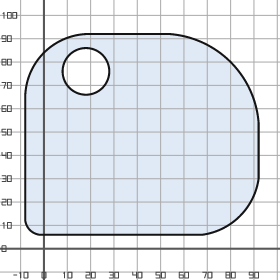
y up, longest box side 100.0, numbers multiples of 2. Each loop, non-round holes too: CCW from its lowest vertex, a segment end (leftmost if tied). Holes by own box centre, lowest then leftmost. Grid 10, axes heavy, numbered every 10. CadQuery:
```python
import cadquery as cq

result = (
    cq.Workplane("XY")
    .moveTo(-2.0, 6.0)
    .lineTo(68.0, 6.0)
    .threePointArc((84.0, 14.0), (92.0, 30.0))
    .lineTo(92.0, 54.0)
    .threePointArc((80.0, 80.0), (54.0, 92.0))
    .lineTo(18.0, 92.0)
    .threePointArc((0.0, 84.0), (-8.0, 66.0))
    .lineTo(-8.0, 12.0)
    .threePointArc((-6.0, 8.0), (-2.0, 6.0))
    .close()
    .moveTo(18.0, 76.0)
    .circle(10.0)
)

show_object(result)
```